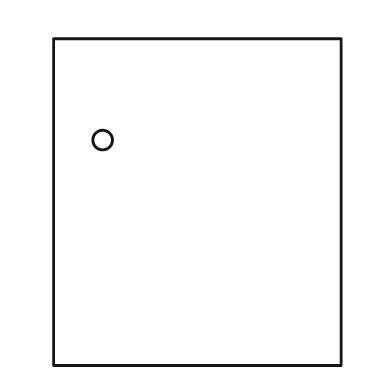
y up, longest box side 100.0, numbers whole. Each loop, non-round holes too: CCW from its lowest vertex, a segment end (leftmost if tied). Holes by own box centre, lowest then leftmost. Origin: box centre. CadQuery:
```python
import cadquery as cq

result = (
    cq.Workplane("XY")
    .moveTo(-44.0, -50.0)
    .lineTo(44.0, -50.0)
    .lineTo(44.0, 50.0)
    .lineTo(-44.0, 50.0)
    .close()
    .moveTo(-29.0, 19.0)
    .circle(3.0)
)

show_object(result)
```